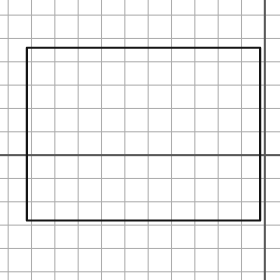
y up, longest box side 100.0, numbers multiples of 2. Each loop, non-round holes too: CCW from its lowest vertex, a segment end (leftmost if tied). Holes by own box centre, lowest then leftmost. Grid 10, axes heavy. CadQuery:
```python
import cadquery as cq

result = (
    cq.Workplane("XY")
    .moveTo(-102.0, -28.0)
    .lineTo(-2.0, -28.0)
    .lineTo(-2.0, 46.0)
    .lineTo(-102.0, 46.0)
    .close()
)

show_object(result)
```